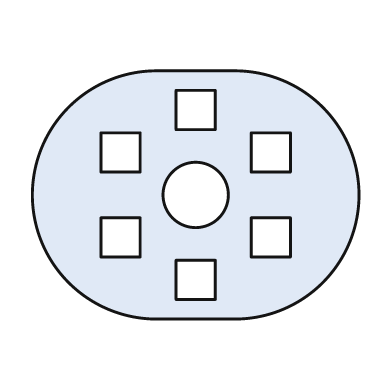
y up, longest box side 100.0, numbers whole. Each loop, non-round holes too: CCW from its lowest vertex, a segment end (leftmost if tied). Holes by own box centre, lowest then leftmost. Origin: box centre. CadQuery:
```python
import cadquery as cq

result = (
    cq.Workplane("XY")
    .moveTo(-12.0, -38.0)
    .lineTo(12.0, -38.0)
    .threePointArc((50.0, 0.0), (12.0, 38.0))
    .lineTo(-12.0, 38.0)
    .threePointArc((-50.0, 0.0), (-12.0, -38.0))
    .close()
    .moveTo(-6.0, -32.0)
    .lineTo(6.0, -32.0)
    .lineTo(6.0, -20.0)
    .lineTo(-6.0, -20.0)
    .close()
    .moveTo(-29.0, -19.0)
    .lineTo(-17.0, -19.0)
    .lineTo(-17.0, -7.0)
    .lineTo(-29.0, -7.0)
    .close()
    .moveTo(17.0, -19.0)
    .lineTo(29.0, -19.0)
    .lineTo(29.0, -7.0)
    .lineTo(17.0, -7.0)
    .close()
    .moveTo(0.0, 0.0)
    .circle(10.0)
    .moveTo(-29.0, 7.0)
    .lineTo(-17.0, 7.0)
    .lineTo(-17.0, 19.0)
    .lineTo(-29.0, 19.0)
    .close()
    .moveTo(17.0, 7.0)
    .lineTo(29.0, 7.0)
    .lineTo(29.0, 19.0)
    .lineTo(17.0, 19.0)
    .close()
    .moveTo(-6.0, 20.0)
    .lineTo(6.0, 20.0)
    .lineTo(6.0, 32.0)
    .lineTo(-6.0, 32.0)
    .close()
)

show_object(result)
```